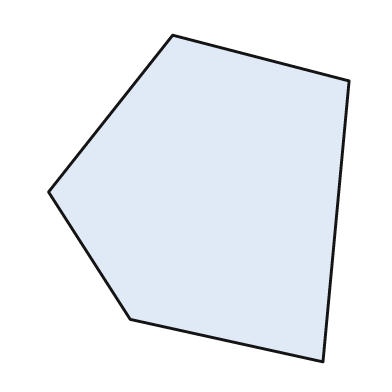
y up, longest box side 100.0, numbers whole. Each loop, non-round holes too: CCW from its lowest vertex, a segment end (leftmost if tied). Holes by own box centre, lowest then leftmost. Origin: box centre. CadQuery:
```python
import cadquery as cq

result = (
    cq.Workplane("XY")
    .moveTo(38.0, -50.0)
    .lineTo(46.0, 36.0)
    .lineTo(-8.0, 50.0)
    .lineTo(-46.0, 2.0)
    .lineTo(-21.0, -37.0)
    .close()
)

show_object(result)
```